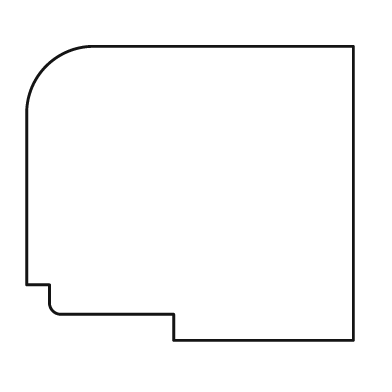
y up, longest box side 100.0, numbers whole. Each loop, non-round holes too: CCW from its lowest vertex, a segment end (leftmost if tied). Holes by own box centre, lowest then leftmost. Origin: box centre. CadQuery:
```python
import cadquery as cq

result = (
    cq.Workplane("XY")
    .moveTo(-5.0, -45.0)
    .lineTo(50.0, -45.0)
    .lineTo(50.0, 45.0)
    .lineTo(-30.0, 45.0)
    .threePointArc((-44.0, 39.0), (-50.0, 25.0))
    .lineTo(-50.0, -28.0)
    .lineTo(-43.0, -28.0)
    .lineTo(-43.0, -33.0)
    .threePointArc((-42.0, -36.0), (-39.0, -37.0))
    .lineTo(-5.0, -37.0)
    .close()
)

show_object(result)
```